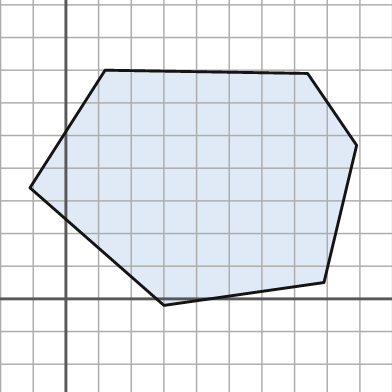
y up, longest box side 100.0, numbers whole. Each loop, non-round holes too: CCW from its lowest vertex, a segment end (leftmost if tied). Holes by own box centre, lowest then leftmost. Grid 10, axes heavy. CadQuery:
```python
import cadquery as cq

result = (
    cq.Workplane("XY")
    .moveTo(30.0, -2.0)
    .lineTo(79.0, 5.0)
    .lineTo(89.0, 47.0)
    .lineTo(74.0, 69.0)
    .lineTo(12.0, 70.0)
    .lineTo(-11.0, 34.0)
    .close()
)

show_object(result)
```